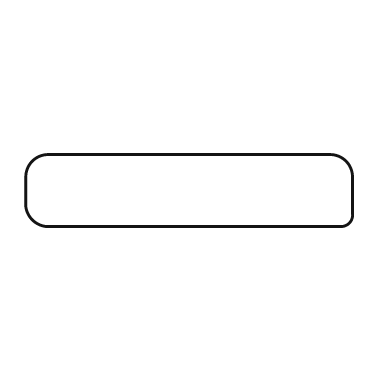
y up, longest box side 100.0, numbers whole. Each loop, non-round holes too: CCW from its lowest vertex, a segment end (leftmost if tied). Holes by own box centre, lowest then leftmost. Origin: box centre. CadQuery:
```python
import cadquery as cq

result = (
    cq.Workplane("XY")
    .moveTo(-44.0, -11.0)
    .lineTo(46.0, -11.0)
    .threePointArc((49.0, -10.0), (50.0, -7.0))
    .lineTo(50.0, 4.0)
    .threePointArc((48.0, 9.0), (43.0, 11.0))
    .lineTo(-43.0, 11.0)
    .threePointArc((-48.0, 9.0), (-50.0, 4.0))
    .lineTo(-50.0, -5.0)
    .threePointArc((-48.0, -9.0), (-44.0, -11.0))
    .close()
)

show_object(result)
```